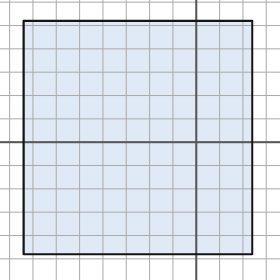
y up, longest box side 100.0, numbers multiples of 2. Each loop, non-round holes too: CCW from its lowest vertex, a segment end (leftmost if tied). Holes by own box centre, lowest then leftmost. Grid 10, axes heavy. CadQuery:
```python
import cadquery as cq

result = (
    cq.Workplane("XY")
    .moveTo(-74.0, -48.0)
    .lineTo(24.0, -48.0)
    .lineTo(24.0, 52.0)
    .lineTo(-74.0, 52.0)
    .close()
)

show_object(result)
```